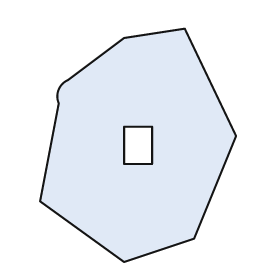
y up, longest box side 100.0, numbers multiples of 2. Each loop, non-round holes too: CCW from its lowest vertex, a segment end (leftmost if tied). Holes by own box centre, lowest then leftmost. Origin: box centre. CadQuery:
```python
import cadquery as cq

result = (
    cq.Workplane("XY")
    .moveTo(-6.0, -50.0)
    .lineTo(24.0, -40.0)
    .lineTo(42.0, 4.0)
    .lineTo(20.0, 50.0)
    .lineTo(-6.0, 46.0)
    .lineTo(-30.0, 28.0)
    .threePointArc((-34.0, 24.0), (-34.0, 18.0))
    .lineTo(-42.0, -24.0)
    .close()
    .moveTo(-6.0, -8.0)
    .lineTo(6.0, -8.0)
    .lineTo(6.0, 8.0)
    .lineTo(-6.0, 8.0)
    .close()
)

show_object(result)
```